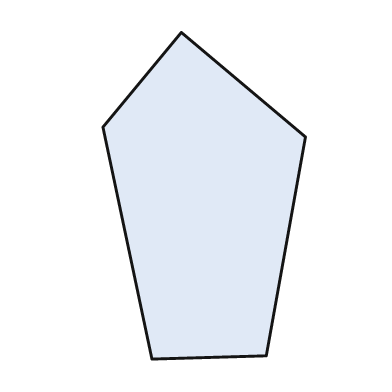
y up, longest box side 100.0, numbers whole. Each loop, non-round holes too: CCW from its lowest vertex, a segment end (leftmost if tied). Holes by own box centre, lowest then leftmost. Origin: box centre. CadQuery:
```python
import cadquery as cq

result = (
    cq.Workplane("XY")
    .moveTo(-16.0, -50.0)
    .lineTo(19.0, -49.0)
    .lineTo(31.0, 18.0)
    .lineTo(-7.0, 50.0)
    .lineTo(-31.0, 21.0)
    .close()
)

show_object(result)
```